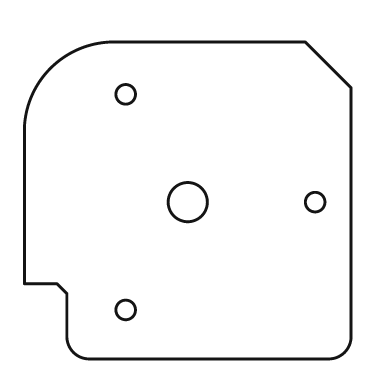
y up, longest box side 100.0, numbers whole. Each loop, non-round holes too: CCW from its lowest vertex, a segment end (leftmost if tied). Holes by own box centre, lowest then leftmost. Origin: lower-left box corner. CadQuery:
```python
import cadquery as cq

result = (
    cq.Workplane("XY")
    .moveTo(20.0, 0.0)
    .lineTo(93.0, 0.0)
    .threePointArc((98.0, 2.0), (100.0, 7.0))
    .lineTo(100.0, 83.0)
    .lineTo(86.0, 97.0)
    .lineTo(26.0, 97.0)
    .threePointArc((8.0, 89.0), (0.0, 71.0))
    .lineTo(0.0, 23.0)
    .lineTo(10.0, 23.0)
    .lineTo(13.0, 20.0)
    .lineTo(13.0, 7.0)
    .threePointArc((15.0, 2.0), (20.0, 0.0))
    .close()
    .moveTo(31.0, 15.0)
    .circle(3.0)
    .moveTo(50.0, 48.0)
    .circle(6.0)
    .moveTo(89.0, 48.0)
    .circle(3.0)
    .moveTo(31.0, 81.0)
    .circle(3.0)
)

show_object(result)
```